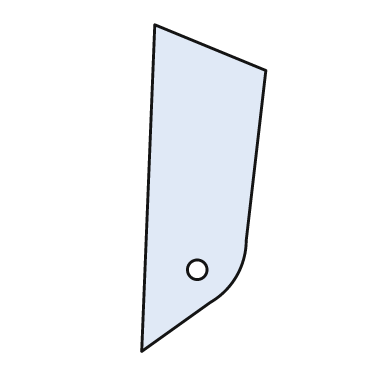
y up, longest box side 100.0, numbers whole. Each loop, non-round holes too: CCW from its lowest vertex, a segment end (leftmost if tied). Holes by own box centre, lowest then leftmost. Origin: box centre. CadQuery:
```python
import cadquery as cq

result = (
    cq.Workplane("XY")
    .moveTo(-19.0, -50.0)
    .lineTo(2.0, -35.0)
    .threePointArc((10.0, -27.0), (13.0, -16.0))
    .lineTo(19.0, 36.0)
    .lineTo(-15.0, 50.0)
    .close()
    .moveTo(-2.0, -25.0)
    .circle(3.0)
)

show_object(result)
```